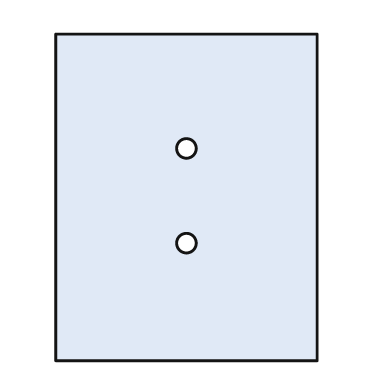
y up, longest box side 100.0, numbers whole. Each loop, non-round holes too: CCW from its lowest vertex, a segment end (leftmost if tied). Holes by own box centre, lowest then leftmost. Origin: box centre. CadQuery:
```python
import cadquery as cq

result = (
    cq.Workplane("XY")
    .moveTo(-40.0, -50.0)
    .lineTo(40.0, -50.0)
    .lineTo(40.0, 50.0)
    .lineTo(-40.0, 50.0)
    .close()
    .moveTo(0.0, -14.0)
    .circle(3.0)
    .moveTo(0.0, 15.0)
    .circle(3.0)
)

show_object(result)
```